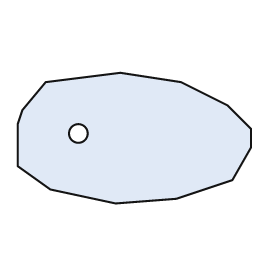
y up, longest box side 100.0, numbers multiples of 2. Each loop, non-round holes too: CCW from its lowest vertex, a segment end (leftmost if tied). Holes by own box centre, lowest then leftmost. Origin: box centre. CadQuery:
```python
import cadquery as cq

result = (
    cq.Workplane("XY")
    .moveTo(-8.0, -28.0)
    .lineTo(18.0, -26.0)
    .lineTo(42.0, -18.0)
    .lineTo(50.0, -4.0)
    .lineTo(50.0, 4.0)
    .lineTo(40.0, 14.0)
    .lineTo(20.0, 24.0)
    .lineTo(-6.0, 28.0)
    .lineTo(-38.0, 24.0)
    .lineTo(-48.0, 12.0)
    .lineTo(-50.0, 6.0)
    .lineTo(-50.0, -12.0)
    .lineTo(-36.0, -22.0)
    .close()
    .moveTo(-24.0, 2.0)
    .circle(4.0)
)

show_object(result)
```